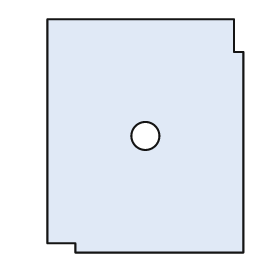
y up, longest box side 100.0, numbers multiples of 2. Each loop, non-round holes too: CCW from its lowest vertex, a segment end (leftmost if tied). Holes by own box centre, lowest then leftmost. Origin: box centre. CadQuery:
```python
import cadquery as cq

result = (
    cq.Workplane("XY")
    .moveTo(-30.0, -50.0)
    .lineTo(42.0, -50.0)
    .lineTo(42.0, 36.0)
    .lineTo(38.0, 36.0)
    .lineTo(38.0, 50.0)
    .lineTo(-42.0, 50.0)
    .lineTo(-42.0, -46.0)
    .lineTo(-30.0, -46.0)
    .close()
    .moveTo(0.0, 0.0)
    .circle(6.0)
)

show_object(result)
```